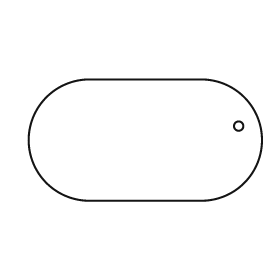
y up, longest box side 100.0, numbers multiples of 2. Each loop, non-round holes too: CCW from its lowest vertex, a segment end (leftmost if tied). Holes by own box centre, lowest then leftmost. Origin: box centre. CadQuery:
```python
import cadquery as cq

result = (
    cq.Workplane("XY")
    .moveTo(-24.0, -26.0)
    .lineTo(24.0, -26.0)
    .threePointArc((50.0, 0.0), (24.0, 26.0))
    .lineTo(-24.0, 26.0)
    .threePointArc((-50.0, 0.0), (-24.0, -26.0))
    .close()
    .moveTo(40.0, 6.0)
    .circle(2.0)
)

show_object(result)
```